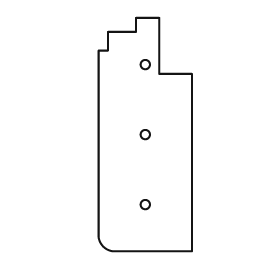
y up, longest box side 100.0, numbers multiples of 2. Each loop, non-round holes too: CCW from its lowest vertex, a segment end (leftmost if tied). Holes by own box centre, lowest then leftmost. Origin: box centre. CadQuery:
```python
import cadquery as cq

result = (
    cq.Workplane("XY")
    .moveTo(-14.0, -50.0)
    .lineTo(20.0, -50.0)
    .lineTo(20.0, 26.0)
    .lineTo(6.0, 26.0)
    .lineTo(6.0, 50.0)
    .lineTo(-4.0, 50.0)
    .lineTo(-4.0, 44.0)
    .lineTo(-16.0, 44.0)
    .lineTo(-16.0, 36.0)
    .lineTo(-20.0, 36.0)
    .lineTo(-20.0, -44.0)
    .threePointArc((-18.0, -48.0), (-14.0, -50.0))
    .close()
    .moveTo(0.0, -30.0)
    .circle(2.0)
    .moveTo(0.0, 0.0)
    .circle(2.0)
    .moveTo(0.0, 30.0)
    .circle(2.0)
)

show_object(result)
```